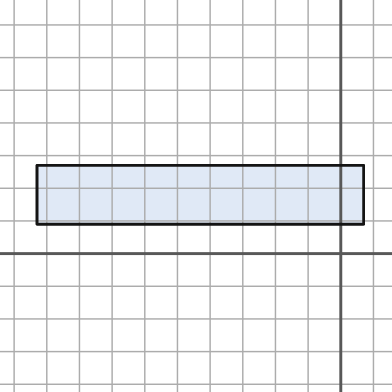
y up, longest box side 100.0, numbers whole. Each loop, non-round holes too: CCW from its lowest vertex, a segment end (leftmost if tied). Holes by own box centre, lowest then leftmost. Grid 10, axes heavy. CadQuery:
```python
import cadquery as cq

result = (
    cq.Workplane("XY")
    .moveTo(-93.0, 9.0)
    .lineTo(7.0, 9.0)
    .lineTo(7.0, 27.0)
    .lineTo(-93.0, 27.0)
    .close()
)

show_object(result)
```